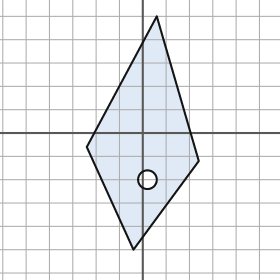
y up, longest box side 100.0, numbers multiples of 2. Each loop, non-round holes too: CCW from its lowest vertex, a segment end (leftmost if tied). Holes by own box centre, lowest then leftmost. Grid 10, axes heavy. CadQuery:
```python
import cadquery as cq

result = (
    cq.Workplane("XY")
    .moveTo(-4.0, -50.0)
    .lineTo(24.0, -12.0)
    .lineTo(6.0, 50.0)
    .lineTo(-24.0, -6.0)
    .close()
    .moveTo(2.0, -20.0)
    .circle(4.0)
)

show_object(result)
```